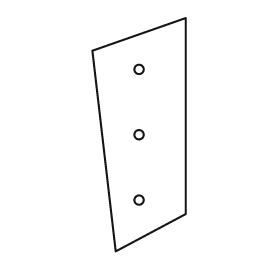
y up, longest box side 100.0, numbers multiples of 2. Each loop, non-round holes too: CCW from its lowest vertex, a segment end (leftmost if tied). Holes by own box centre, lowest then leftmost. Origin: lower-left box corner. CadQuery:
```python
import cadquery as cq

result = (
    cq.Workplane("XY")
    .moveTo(10.0, 0.0)
    .lineTo(40.0, 16.0)
    .lineTo(40.0, 100.0)
    .lineTo(0.0, 86.0)
    .close()
    .moveTo(20.0, 22.0)
    .circle(2.0)
    .moveTo(20.0, 50.0)
    .circle(2.0)
    .moveTo(20.0, 78.0)
    .circle(2.0)
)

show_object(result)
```